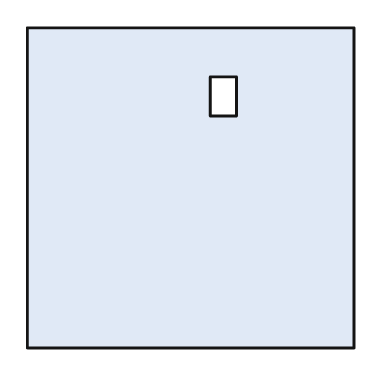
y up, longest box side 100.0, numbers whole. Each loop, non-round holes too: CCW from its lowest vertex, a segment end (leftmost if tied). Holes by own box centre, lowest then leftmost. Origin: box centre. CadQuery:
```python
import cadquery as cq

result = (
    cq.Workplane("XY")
    .moveTo(-50.0, -49.0)
    .lineTo(50.0, -49.0)
    .lineTo(50.0, 49.0)
    .lineTo(-50.0, 49.0)
    .close()
    .moveTo(6.0, 22.0)
    .lineTo(14.0, 22.0)
    .lineTo(14.0, 34.0)
    .lineTo(6.0, 34.0)
    .close()
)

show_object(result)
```